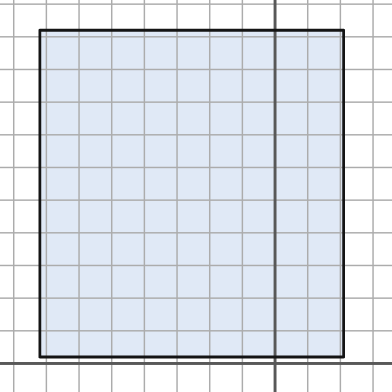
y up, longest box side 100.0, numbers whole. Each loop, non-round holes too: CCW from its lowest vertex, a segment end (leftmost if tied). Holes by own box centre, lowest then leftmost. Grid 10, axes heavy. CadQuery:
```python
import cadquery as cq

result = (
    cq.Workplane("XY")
    .moveTo(-72.0, 2.0)
    .lineTo(21.0, 2.0)
    .lineTo(21.0, 102.0)
    .lineTo(-72.0, 102.0)
    .close()
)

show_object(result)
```